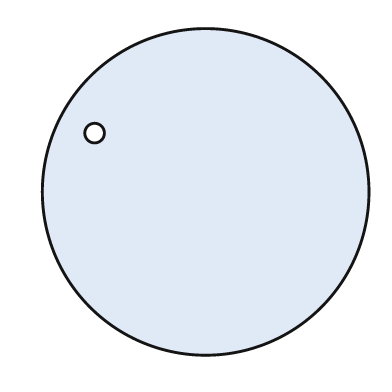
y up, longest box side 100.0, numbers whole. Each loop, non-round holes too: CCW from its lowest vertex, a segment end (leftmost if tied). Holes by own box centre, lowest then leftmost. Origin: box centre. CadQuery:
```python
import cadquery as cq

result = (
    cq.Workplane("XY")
    .moveTo(0.0, 0.0)
    .circle(50.0)
    .moveTo(-34.0, 18.0)
    .circle(3.0)
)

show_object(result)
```